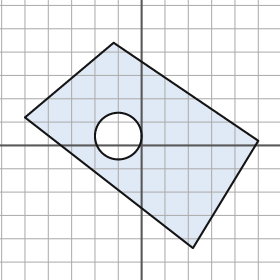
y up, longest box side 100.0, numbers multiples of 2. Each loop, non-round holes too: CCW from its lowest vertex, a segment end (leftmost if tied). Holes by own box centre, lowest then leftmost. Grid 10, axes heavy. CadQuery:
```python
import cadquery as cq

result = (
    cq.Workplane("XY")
    .moveTo(22.0, -44.0)
    .lineTo(50.0, 2.0)
    .lineTo(-12.0, 44.0)
    .lineTo(-50.0, 12.0)
    .close()
    .moveTo(-10.0, 4.0)
    .circle(10.0)
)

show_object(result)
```